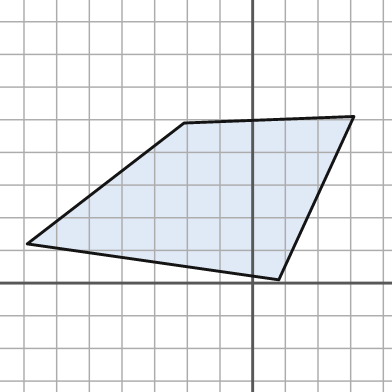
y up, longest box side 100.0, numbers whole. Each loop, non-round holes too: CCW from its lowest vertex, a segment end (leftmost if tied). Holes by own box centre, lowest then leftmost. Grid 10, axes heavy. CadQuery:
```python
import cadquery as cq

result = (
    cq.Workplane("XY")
    .moveTo(8.0, 1.0)
    .lineTo(31.0, 51.0)
    .lineTo(-21.0, 49.0)
    .lineTo(-69.0, 12.0)
    .close()
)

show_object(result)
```